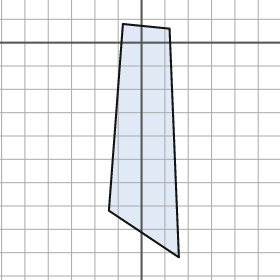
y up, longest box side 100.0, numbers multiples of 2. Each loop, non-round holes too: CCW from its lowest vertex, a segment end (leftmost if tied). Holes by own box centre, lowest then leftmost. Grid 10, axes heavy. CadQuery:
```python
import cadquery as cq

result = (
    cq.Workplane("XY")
    .moveTo(16.0, -92.0)
    .lineTo(12.0, 6.0)
    .lineTo(-8.0, 8.0)
    .lineTo(-14.0, -72.0)
    .close()
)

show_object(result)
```